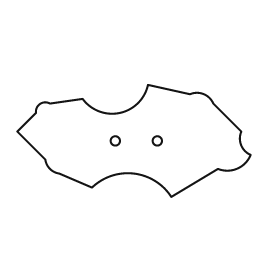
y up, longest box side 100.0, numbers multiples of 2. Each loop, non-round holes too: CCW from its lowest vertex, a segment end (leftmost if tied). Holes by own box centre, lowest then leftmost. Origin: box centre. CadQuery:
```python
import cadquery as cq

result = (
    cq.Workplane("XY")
    .moveTo(16.0, -24.0)
    .lineTo(36.0, -12.0)
    .threePointArc((44.0, -12.0), (50.0, -6.0))
    .threePointArc((46.0, -2.0), (46.0, 4.0))
    .lineTo(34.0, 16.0)
    .threePointArc((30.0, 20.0), (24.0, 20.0))
    .lineTo(6.0, 24.0)
    .threePointArc((-6.0, 12.0), (-22.0, 18.0))
    .lineTo(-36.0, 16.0)
    .threePointArc((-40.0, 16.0), (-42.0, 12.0))
    .lineTo(-50.0, 4.0)
    .lineTo(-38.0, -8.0)
    .threePointArc((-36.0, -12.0), (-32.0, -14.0))
    .lineTo(-18.0, -20.0)
    .threePointArc((0.0, -14.0), (16.0, -24.0))
    .close()
    .moveTo(-8.0, 0.0)
    .circle(2.0)
    .moveTo(10.0, 0.0)
    .circle(2.0)
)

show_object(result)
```